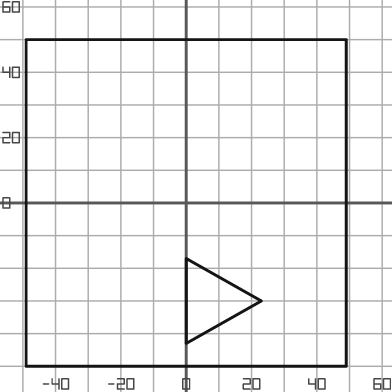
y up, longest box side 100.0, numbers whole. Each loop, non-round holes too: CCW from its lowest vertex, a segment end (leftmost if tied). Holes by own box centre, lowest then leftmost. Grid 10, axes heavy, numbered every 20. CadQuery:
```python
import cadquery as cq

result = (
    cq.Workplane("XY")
    .moveTo(-49.0, -50.0)
    .lineTo(49.0, -50.0)
    .lineTo(49.0, 50.0)
    .lineTo(-49.0, 50.0)
    .close()
    .moveTo(0.0, -43.0)
    .lineTo(23.0, -30.0)
    .lineTo(0.0, -17.0)
    .close()
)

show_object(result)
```